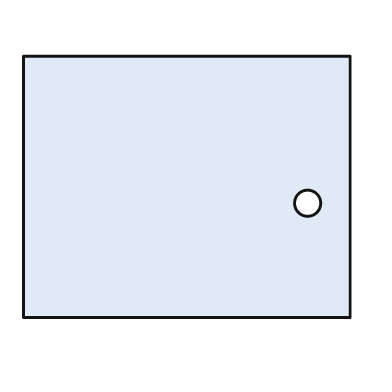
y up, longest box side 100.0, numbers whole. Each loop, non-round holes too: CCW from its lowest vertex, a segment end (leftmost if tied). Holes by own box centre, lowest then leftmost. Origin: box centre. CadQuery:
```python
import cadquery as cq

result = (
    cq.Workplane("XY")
    .moveTo(-50.0, -40.0)
    .lineTo(50.0, -40.0)
    .lineTo(50.0, 40.0)
    .lineTo(-50.0, 40.0)
    .close()
    .moveTo(37.0, -5.0)
    .circle(4.0)
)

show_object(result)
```